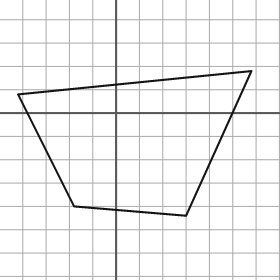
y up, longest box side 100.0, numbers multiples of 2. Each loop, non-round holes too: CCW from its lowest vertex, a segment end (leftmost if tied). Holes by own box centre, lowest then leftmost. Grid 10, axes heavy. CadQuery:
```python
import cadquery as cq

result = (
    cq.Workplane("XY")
    .moveTo(30.0, -44.0)
    .lineTo(58.0, 18.0)
    .lineTo(-42.0, 8.0)
    .lineTo(-18.0, -40.0)
    .close()
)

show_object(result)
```